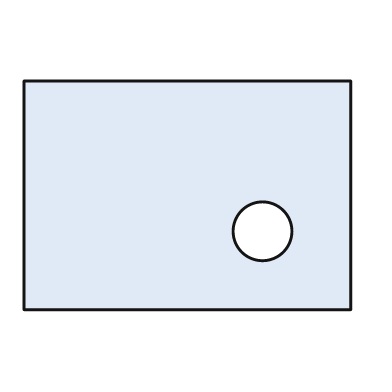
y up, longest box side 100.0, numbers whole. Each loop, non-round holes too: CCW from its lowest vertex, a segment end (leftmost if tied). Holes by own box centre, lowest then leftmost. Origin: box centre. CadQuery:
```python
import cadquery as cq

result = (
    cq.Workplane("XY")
    .moveTo(-50.0, -35.0)
    .lineTo(50.0, -35.0)
    .lineTo(50.0, 35.0)
    .lineTo(-50.0, 35.0)
    .close()
    .moveTo(23.0, -11.0)
    .circle(9.0)
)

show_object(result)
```